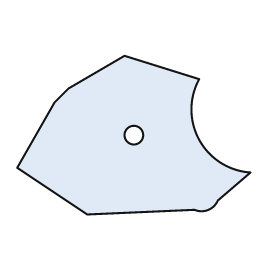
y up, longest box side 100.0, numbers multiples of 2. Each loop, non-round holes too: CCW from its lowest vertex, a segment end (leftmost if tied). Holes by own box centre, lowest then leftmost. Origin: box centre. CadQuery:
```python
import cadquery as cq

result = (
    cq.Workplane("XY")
    .moveTo(-20.0, -34.0)
    .lineTo(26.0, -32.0)
    .threePointArc((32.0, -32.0), (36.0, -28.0))
    .lineTo(50.0, -16.0)
    .threePointArc((28.0, -2.0), (28.0, 24.0))
    .lineTo(-4.0, 34.0)
    .lineTo(-28.0, 20.0)
    .lineTo(-34.0, 14.0)
    .lineTo(-50.0, -14.0)
    .close()
    .moveTo(0.0, 0.0)
    .circle(4.0)
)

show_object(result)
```